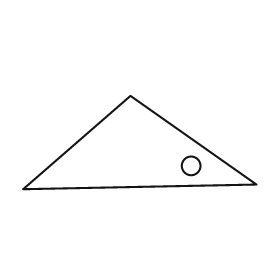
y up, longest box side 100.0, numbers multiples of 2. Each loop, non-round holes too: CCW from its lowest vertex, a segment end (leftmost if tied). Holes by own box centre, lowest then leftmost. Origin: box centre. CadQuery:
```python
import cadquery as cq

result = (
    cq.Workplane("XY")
    .moveTo(-50.0, -20.0)
    .lineTo(50.0, -18.0)
    .lineTo(-4.0, 20.0)
    .close()
    .moveTo(22.0, -10.0)
    .circle(4.0)
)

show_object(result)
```